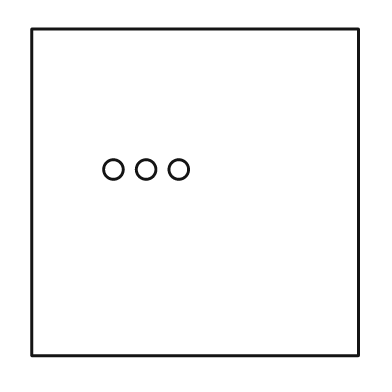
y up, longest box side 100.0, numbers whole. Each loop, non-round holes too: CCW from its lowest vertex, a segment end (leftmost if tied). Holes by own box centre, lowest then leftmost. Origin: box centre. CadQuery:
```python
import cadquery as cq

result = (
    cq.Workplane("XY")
    .moveTo(-50.0, -50.0)
    .lineTo(50.0, -50.0)
    .lineTo(50.0, 50.0)
    .lineTo(-50.0, 50.0)
    .close()
    .moveTo(-25.0, 7.0)
    .circle(3.0)
    .moveTo(-15.0, 7.0)
    .circle(3.0)
    .moveTo(-5.0, 7.0)
    .circle(3.0)
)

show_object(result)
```